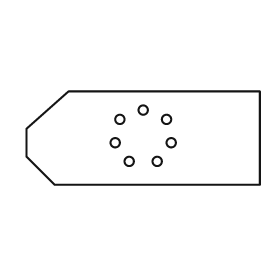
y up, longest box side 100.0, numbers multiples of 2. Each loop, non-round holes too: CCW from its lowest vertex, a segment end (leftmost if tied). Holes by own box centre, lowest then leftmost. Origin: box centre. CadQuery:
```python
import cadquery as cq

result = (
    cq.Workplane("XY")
    .moveTo(-38.0, -20.0)
    .lineTo(50.0, -20.0)
    .lineTo(50.0, 20.0)
    .lineTo(-32.0, 20.0)
    .lineTo(-50.0, 4.0)
    .lineTo(-50.0, -8.0)
    .close()
    .moveTo(-6.0, -10.0)
    .circle(2.0)
    .moveTo(6.0, -10.0)
    .circle(2.0)
    .moveTo(-12.0, -2.0)
    .circle(2.0)
    .moveTo(12.0, -2.0)
    .circle(2.0)
    .moveTo(-10.0, 8.0)
    .circle(2.0)
    .moveTo(10.0, 8.0)
    .circle(2.0)
    .moveTo(0.0, 12.0)
    .circle(2.0)
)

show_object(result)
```